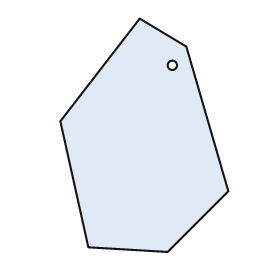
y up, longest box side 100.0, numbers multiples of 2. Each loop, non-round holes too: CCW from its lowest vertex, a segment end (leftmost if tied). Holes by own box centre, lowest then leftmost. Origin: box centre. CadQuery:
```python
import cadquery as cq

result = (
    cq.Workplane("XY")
    .moveTo(10.0, -50.0)
    .lineTo(36.0, -24.0)
    .lineTo(18.0, 38.0)
    .lineTo(-2.0, 50.0)
    .lineTo(-36.0, 6.0)
    .lineTo(-24.0, -48.0)
    .close()
    .moveTo(12.0, 30.0)
    .circle(2.0)
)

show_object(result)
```